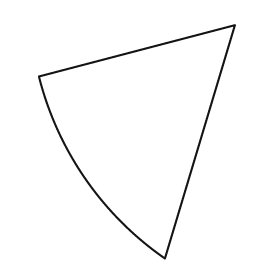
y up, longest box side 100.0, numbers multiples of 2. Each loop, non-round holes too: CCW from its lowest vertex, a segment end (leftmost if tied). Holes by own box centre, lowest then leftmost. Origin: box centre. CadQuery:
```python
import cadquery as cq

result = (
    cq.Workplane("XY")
    .moveTo(12.0, -50.0)
    .lineTo(42.0, 50.0)
    .lineTo(-42.0, 28.0)
    .threePointArc((-22.0, -16.0), (12.0, -50.0))
    .close()
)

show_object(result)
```